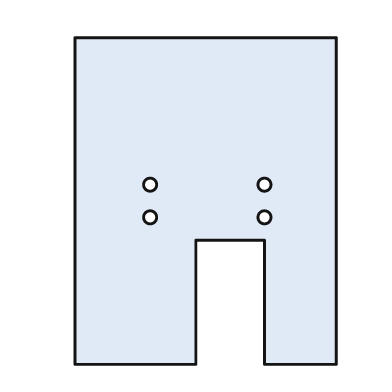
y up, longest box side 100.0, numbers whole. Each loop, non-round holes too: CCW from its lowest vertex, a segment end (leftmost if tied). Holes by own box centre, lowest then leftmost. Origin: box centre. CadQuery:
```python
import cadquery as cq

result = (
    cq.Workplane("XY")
    .moveTo(-40.0, -50.0)
    .lineTo(-3.0, -50.0)
    .lineTo(-3.0, -12.0)
    .lineTo(18.0, -12.0)
    .lineTo(18.0, -50.0)
    .lineTo(40.0, -50.0)
    .lineTo(40.0, 50.0)
    .lineTo(-40.0, 50.0)
    .close()
    .moveTo(-17.0, -5.0)
    .circle(2.0)
    .moveTo(18.0, -5.0)
    .circle(2.0)
    .moveTo(-17.0, 5.0)
    .circle(2.0)
    .moveTo(18.0, 5.0)
    .circle(2.0)
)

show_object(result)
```